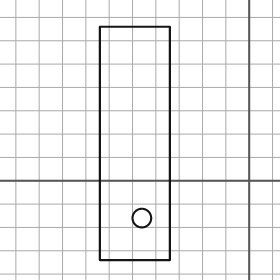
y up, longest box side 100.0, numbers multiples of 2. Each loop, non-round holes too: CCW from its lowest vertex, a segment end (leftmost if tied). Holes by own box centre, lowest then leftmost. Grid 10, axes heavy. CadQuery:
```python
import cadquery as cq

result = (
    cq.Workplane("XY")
    .moveTo(-64.0, -34.0)
    .lineTo(-34.0, -34.0)
    .lineTo(-34.0, 66.0)
    .lineTo(-64.0, 66.0)
    .close()
    .moveTo(-46.0, -16.0)
    .circle(4.0)
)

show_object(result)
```